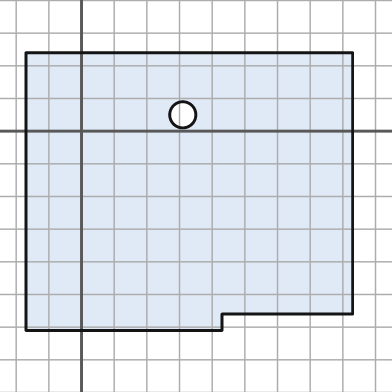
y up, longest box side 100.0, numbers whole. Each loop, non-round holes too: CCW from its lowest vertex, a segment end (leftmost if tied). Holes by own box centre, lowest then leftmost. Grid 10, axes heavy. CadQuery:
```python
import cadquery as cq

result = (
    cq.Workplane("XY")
    .moveTo(-17.0, -61.0)
    .lineTo(43.0, -61.0)
    .lineTo(43.0, -56.0)
    .lineTo(83.0, -56.0)
    .lineTo(83.0, 24.0)
    .lineTo(-17.0, 24.0)
    .close()
    .moveTo(31.0, 5.0)
    .circle(4.0)
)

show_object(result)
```